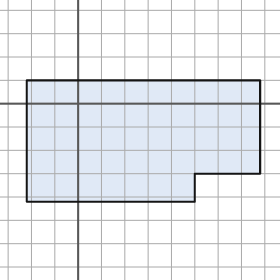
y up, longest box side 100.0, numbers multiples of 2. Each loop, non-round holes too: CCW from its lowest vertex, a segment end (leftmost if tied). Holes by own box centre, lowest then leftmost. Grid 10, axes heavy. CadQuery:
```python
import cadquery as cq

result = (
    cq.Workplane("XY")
    .moveTo(-22.0, -42.0)
    .lineTo(50.0, -42.0)
    .lineTo(50.0, -30.0)
    .lineTo(78.0, -30.0)
    .lineTo(78.0, 10.0)
    .lineTo(-22.0, 10.0)
    .close()
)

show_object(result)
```